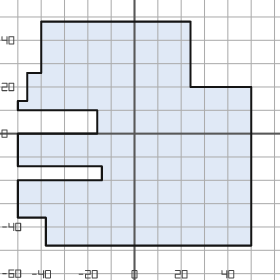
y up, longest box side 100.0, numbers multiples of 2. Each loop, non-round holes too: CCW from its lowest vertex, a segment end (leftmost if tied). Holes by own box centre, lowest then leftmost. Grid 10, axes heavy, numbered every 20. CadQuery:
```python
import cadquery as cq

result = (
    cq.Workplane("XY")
    .moveTo(-38.0, -48.0)
    .lineTo(50.0, -48.0)
    .lineTo(50.0, 20.0)
    .lineTo(24.0, 20.0)
    .lineTo(24.0, 48.0)
    .lineTo(-40.0, 48.0)
    .lineTo(-40.0, 26.0)
    .lineTo(-46.0, 26.0)
    .lineTo(-46.0, 14.0)
    .lineTo(-50.0, 14.0)
    .lineTo(-50.0, 10.0)
    .lineTo(-16.0, 10.0)
    .lineTo(-16.0, 0.0)
    .lineTo(-50.0, 0.0)
    .lineTo(-50.0, -14.0)
    .lineTo(-14.0, -14.0)
    .lineTo(-14.0, -20.0)
    .lineTo(-50.0, -20.0)
    .lineTo(-50.0, -36.0)
    .lineTo(-38.0, -36.0)
    .close()
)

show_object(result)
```